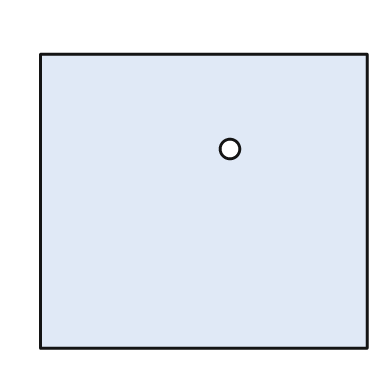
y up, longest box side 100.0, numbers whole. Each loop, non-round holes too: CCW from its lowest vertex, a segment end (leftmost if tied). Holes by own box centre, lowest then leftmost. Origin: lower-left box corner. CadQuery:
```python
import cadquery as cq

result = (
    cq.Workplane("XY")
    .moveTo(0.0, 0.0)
    .lineTo(100.0, 0.0)
    .lineTo(100.0, 90.0)
    .lineTo(0.0, 90.0)
    .close()
    .moveTo(58.0, 61.0)
    .circle(3.0)
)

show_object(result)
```